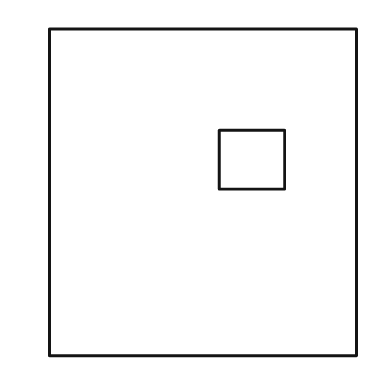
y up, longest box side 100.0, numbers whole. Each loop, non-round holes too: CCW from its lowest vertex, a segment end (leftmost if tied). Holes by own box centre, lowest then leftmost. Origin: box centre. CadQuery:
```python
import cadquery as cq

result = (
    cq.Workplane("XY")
    .moveTo(-47.0, -50.0)
    .lineTo(47.0, -50.0)
    .lineTo(47.0, 50.0)
    .lineTo(-47.0, 50.0)
    .close()
    .moveTo(5.0, 1.0)
    .lineTo(25.0, 1.0)
    .lineTo(25.0, 19.0)
    .lineTo(5.0, 19.0)
    .close()
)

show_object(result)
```